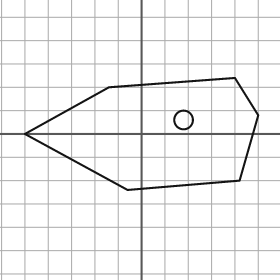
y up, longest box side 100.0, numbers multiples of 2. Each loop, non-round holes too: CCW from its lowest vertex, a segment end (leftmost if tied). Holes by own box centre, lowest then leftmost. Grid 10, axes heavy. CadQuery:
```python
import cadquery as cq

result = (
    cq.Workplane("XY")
    .moveTo(-6.0, -24.0)
    .lineTo(42.0, -20.0)
    .lineTo(50.0, 8.0)
    .lineTo(40.0, 24.0)
    .lineTo(-14.0, 20.0)
    .lineTo(-50.0, 0.0)
    .close()
    .moveTo(18.0, 6.0)
    .circle(4.0)
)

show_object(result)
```